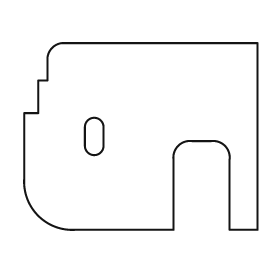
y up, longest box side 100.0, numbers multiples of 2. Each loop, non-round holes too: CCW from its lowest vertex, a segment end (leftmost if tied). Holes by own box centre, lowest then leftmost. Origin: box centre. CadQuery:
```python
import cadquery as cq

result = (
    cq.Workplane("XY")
    .moveTo(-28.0, -40.0)
    .lineTo(14.0, -40.0)
    .lineTo(14.0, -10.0)
    .threePointArc((16.0, -4.0), (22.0, -2.0))
    .lineTo(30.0, -2.0)
    .threePointArc((36.0, -4.0), (38.0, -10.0))
    .lineTo(38.0, -40.0)
    .lineTo(50.0, -40.0)
    .lineTo(50.0, 40.0)
    .lineTo(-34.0, 40.0)
    .threePointArc((-38.0, 38.0), (-40.0, 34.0))
    .lineTo(-40.0, 24.0)
    .lineTo(-44.0, 24.0)
    .lineTo(-44.0, 10.0)
    .lineTo(-50.0, 10.0)
    .lineTo(-50.0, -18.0)
    .threePointArc((-44.0, -34.0), (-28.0, -40.0))
    .close()
    .moveTo(-24.0, -4.0)
    .threePointArc((-20.0, -8.0), (-16.0, -4.0))
    .lineTo(-16.0, 4.0)
    .threePointArc((-20.0, 8.0), (-24.0, 4.0))
    .close()
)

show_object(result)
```